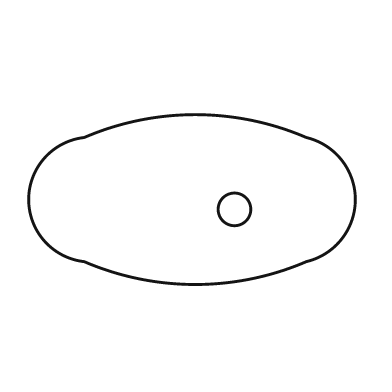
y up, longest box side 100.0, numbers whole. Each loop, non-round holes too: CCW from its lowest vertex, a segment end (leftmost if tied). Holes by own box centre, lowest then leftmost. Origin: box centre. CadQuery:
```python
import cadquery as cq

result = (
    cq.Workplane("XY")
    .moveTo(-33.0, -19.0)
    .threePointArc((1.0, -26.0), (35.0, -19.0))
    .threePointArc((50.0, 0.0), (35.0, 19.0))
    .threePointArc((1.0, 26.0), (-33.0, 19.0))
    .threePointArc((-50.0, 0.0), (-33.0, -19.0))
    .close()
    .moveTo(13.0, -3.0)
    .circle(5.0)
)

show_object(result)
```